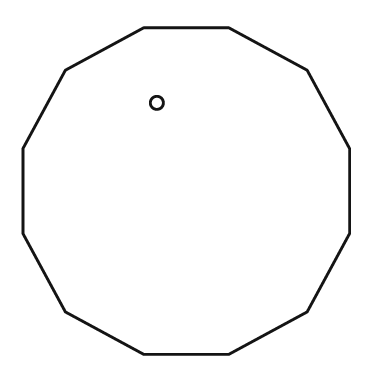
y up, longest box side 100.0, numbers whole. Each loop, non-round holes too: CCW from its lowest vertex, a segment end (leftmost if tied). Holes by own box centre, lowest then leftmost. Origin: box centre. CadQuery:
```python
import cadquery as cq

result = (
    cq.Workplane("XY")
    .moveTo(-13.0, -50.0)
    .lineTo(13.0, -50.0)
    .lineTo(37.0, -37.0)
    .lineTo(50.0, -13.0)
    .lineTo(50.0, 13.0)
    .lineTo(37.0, 37.0)
    .lineTo(13.0, 50.0)
    .lineTo(-13.0, 50.0)
    .lineTo(-37.0, 37.0)
    .lineTo(-50.0, 13.0)
    .lineTo(-50.0, -13.0)
    .lineTo(-37.0, -37.0)
    .close()
    .moveTo(-9.0, 27.0)
    .circle(2.0)
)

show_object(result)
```